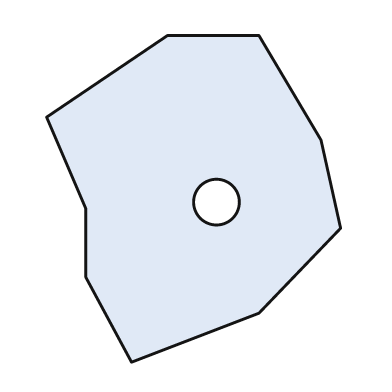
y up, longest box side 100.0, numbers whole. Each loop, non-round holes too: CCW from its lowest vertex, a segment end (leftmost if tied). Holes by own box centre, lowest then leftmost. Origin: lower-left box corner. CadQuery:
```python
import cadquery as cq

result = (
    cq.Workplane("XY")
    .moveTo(26.0, 0.0)
    .lineTo(65.0, 15.0)
    .lineTo(90.0, 41.0)
    .lineTo(84.0, 68.0)
    .lineTo(65.0, 100.0)
    .lineTo(37.0, 100.0)
    .lineTo(0.0, 75.0)
    .lineTo(12.0, 47.0)
    .lineTo(12.0, 26.0)
    .close()
    .moveTo(52.0, 49.0)
    .circle(7.0)
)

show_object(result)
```